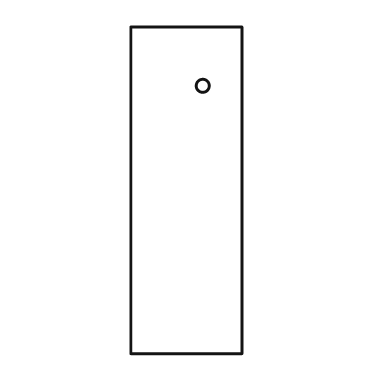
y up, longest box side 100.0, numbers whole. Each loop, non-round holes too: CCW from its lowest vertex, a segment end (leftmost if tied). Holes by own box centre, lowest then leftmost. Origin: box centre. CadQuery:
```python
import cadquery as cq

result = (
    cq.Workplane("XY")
    .moveTo(-17.0, -50.0)
    .lineTo(17.0, -50.0)
    .lineTo(17.0, 50.0)
    .lineTo(-17.0, 50.0)
    .close()
    .moveTo(5.0, 32.0)
    .circle(2.0)
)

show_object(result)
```